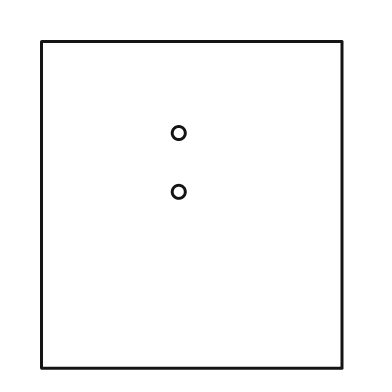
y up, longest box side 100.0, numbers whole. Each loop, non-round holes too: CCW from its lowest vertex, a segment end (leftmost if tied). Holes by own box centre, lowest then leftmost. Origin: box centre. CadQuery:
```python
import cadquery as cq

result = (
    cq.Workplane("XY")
    .moveTo(-46.0, -50.0)
    .lineTo(46.0, -50.0)
    .lineTo(46.0, 50.0)
    .lineTo(-46.0, 50.0)
    .close()
    .moveTo(-4.0, 4.0)
    .circle(2.0)
    .moveTo(-4.0, 22.0)
    .circle(2.0)
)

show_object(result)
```